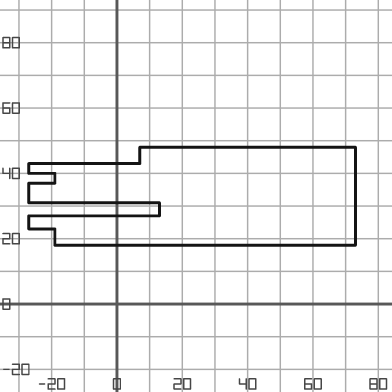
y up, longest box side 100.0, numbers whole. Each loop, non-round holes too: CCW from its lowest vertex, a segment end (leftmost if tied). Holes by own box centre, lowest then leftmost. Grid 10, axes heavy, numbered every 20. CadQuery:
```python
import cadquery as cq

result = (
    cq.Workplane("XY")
    .moveTo(-19.0, 18.0)
    .lineTo(73.0, 18.0)
    .lineTo(73.0, 48.0)
    .lineTo(7.0, 48.0)
    .lineTo(7.0, 43.0)
    .lineTo(-27.0, 43.0)
    .lineTo(-27.0, 40.0)
    .lineTo(-19.0, 40.0)
    .lineTo(-19.0, 37.0)
    .lineTo(-27.0, 37.0)
    .lineTo(-27.0, 31.0)
    .lineTo(13.0, 31.0)
    .lineTo(13.0, 27.0)
    .lineTo(-27.0, 27.0)
    .lineTo(-27.0, 23.0)
    .lineTo(-19.0, 23.0)
    .close()
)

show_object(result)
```